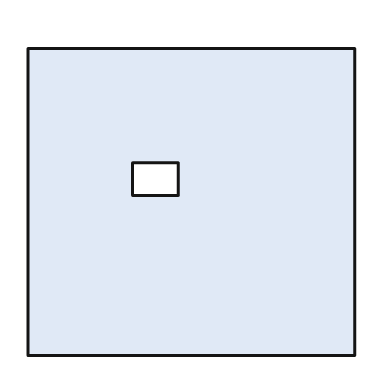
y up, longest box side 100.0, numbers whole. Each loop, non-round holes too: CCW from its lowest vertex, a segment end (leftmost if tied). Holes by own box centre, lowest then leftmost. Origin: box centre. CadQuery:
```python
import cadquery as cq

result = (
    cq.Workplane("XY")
    .moveTo(-50.0, -47.0)
    .lineTo(50.0, -47.0)
    .lineTo(50.0, 47.0)
    .lineTo(-50.0, 47.0)
    .close()
    .moveTo(-18.0, 2.0)
    .lineTo(-4.0, 2.0)
    .lineTo(-4.0, 12.0)
    .lineTo(-18.0, 12.0)
    .close()
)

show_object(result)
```